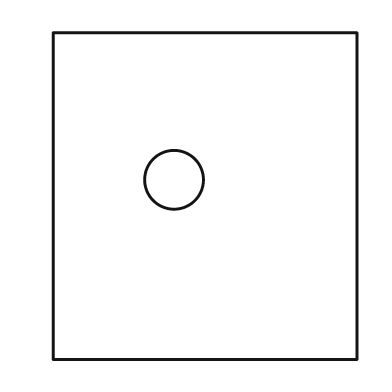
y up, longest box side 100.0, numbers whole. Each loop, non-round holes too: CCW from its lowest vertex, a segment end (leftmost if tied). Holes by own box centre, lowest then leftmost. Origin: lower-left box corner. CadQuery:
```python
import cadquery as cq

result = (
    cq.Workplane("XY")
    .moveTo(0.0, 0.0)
    .lineTo(93.0, 0.0)
    .lineTo(93.0, 100.0)
    .lineTo(0.0, 100.0)
    .close()
    .moveTo(37.0, 55.0)
    .circle(9.0)
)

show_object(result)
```